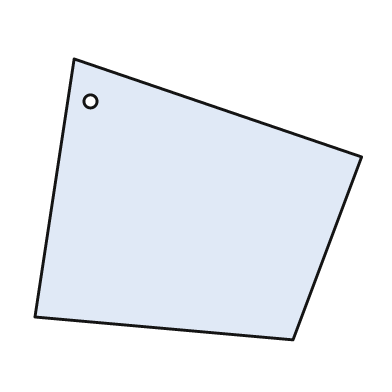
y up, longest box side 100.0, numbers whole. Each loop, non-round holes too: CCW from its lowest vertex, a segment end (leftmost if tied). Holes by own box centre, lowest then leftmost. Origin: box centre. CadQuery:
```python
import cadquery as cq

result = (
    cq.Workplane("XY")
    .moveTo(29.0, -43.0)
    .lineTo(50.0, 13.0)
    .lineTo(-38.0, 43.0)
    .lineTo(-50.0, -36.0)
    .close()
    .moveTo(-33.0, 30.0)
    .circle(2.0)
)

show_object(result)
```